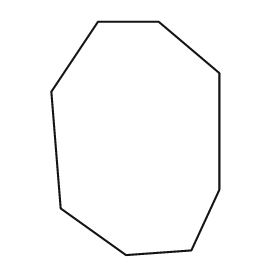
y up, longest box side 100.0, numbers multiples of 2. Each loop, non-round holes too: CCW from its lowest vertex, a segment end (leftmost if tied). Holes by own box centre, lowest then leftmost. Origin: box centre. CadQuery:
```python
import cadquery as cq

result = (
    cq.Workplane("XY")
    .moveTo(-4.0, -50.0)
    .lineTo(24.0, -48.0)
    .lineTo(36.0, -22.0)
    .lineTo(36.0, 28.0)
    .lineTo(10.0, 50.0)
    .lineTo(-16.0, 50.0)
    .lineTo(-36.0, 20.0)
    .lineTo(-32.0, -30.0)
    .close()
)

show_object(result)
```